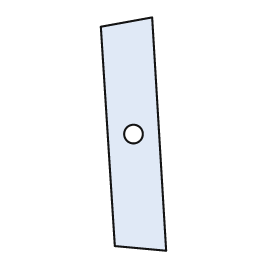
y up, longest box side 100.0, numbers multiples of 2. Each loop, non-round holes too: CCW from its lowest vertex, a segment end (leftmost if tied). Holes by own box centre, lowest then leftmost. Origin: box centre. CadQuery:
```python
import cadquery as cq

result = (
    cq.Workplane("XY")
    .moveTo(14.0, -50.0)
    .lineTo(8.0, 50.0)
    .lineTo(-14.0, 46.0)
    .lineTo(-8.0, -48.0)
    .close()
    .moveTo(0.0, 0.0)
    .circle(4.0)
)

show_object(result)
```